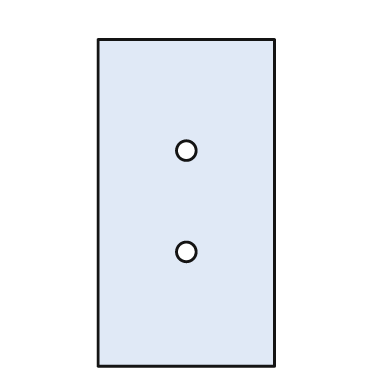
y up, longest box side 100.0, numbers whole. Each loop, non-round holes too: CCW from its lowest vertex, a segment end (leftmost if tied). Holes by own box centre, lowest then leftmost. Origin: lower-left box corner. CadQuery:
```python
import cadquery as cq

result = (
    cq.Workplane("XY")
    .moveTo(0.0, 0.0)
    .lineTo(54.0, 0.0)
    .lineTo(54.0, 100.0)
    .lineTo(0.0, 100.0)
    .close()
    .moveTo(27.0, 35.0)
    .circle(3.0)
    .moveTo(27.0, 66.0)
    .circle(3.0)
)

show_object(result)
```